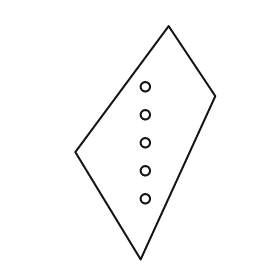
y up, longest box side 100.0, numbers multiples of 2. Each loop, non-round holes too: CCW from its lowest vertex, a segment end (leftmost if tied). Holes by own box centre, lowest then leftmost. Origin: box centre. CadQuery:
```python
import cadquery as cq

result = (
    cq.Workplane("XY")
    .moveTo(-2.0, -50.0)
    .lineTo(30.0, 20.0)
    .lineTo(10.0, 50.0)
    .lineTo(-30.0, -4.0)
    .close()
    .moveTo(0.0, -24.0)
    .circle(2.0)
    .moveTo(0.0, -12.0)
    .circle(2.0)
    .moveTo(0.0, 0.0)
    .circle(2.0)
    .moveTo(0.0, 12.0)
    .circle(2.0)
    .moveTo(0.0, 24.0)
    .circle(2.0)
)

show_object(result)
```